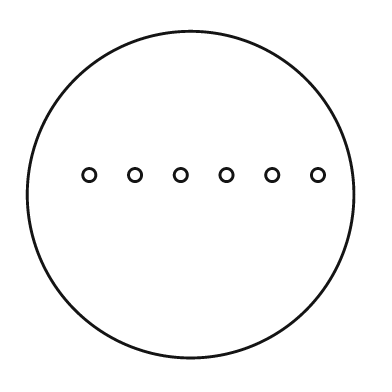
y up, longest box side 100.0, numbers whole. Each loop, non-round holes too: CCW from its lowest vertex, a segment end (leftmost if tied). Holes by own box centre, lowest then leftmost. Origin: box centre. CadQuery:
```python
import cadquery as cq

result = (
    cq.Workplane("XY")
    .moveTo(0.0, 0.0)
    .circle(50.0)
    .moveTo(-31.0, 6.0)
    .circle(2.0)
    .moveTo(-17.0, 6.0)
    .circle(2.0)
    .moveTo(-3.0, 6.0)
    .circle(2.0)
    .moveTo(11.0, 6.0)
    .circle(2.0)
    .moveTo(25.0, 6.0)
    .circle(2.0)
    .moveTo(39.0, 6.0)
    .circle(2.0)
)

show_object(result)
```